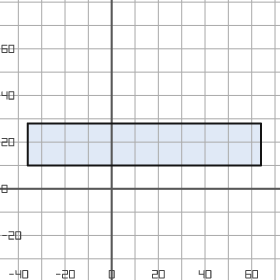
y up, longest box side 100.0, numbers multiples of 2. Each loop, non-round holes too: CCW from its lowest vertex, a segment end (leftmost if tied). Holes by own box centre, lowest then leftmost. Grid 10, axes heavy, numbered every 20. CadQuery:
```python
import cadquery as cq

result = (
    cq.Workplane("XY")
    .moveTo(-36.0, 10.0)
    .lineTo(64.0, 10.0)
    .lineTo(64.0, 28.0)
    .lineTo(-36.0, 28.0)
    .close()
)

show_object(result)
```